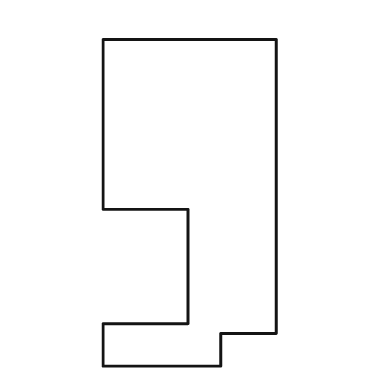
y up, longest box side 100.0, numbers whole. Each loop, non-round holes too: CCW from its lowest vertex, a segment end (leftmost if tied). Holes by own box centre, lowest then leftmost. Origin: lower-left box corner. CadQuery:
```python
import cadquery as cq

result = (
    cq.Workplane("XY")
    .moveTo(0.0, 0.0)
    .lineTo(36.0, 0.0)
    .lineTo(36.0, 10.0)
    .lineTo(53.0, 10.0)
    .lineTo(53.0, 100.0)
    .lineTo(0.0, 100.0)
    .lineTo(0.0, 48.0)
    .lineTo(26.0, 48.0)
    .lineTo(26.0, 13.0)
    .lineTo(0.0, 13.0)
    .close()
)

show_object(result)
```